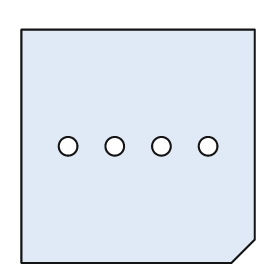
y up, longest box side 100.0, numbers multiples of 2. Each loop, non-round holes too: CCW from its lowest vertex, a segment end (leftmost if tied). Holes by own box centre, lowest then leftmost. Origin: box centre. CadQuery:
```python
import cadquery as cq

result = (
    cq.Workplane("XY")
    .moveTo(-50.0, -50.0)
    .lineTo(40.0, -50.0)
    .lineTo(50.0, -40.0)
    .lineTo(50.0, 50.0)
    .lineTo(-50.0, 50.0)
    .close()
    .moveTo(-30.0, 0.0)
    .circle(4.0)
    .moveTo(-10.0, 0.0)
    .circle(4.0)
    .moveTo(10.0, 0.0)
    .circle(4.0)
    .moveTo(30.0, 0.0)
    .circle(4.0)
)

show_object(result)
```